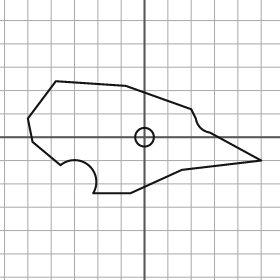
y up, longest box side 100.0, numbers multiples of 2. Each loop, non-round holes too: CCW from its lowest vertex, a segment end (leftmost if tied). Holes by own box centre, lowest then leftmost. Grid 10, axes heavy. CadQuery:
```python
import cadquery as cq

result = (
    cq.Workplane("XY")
    .moveTo(-22.0, -24.0)
    .lineTo(-6.0, -24.0)
    .lineTo(16.0, -14.0)
    .lineTo(50.0, -10.0)
    .lineTo(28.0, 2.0)
    .threePointArc((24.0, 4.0), (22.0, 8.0))
    .lineTo(20.0, 12.0)
    .lineTo(-8.0, 22.0)
    .lineTo(-38.0, 24.0)
    .lineTo(-50.0, 8.0)
    .lineTo(-48.0, -2.0)
    .lineTo(-36.0, -12.0)
    .threePointArc((-24.0, -12.0), (-22.0, -24.0))
    .close()
    .moveTo(0.0, 0.0)
    .circle(4.0)
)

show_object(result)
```